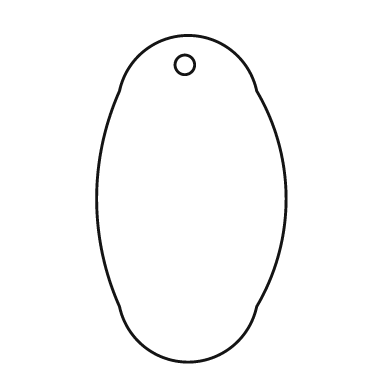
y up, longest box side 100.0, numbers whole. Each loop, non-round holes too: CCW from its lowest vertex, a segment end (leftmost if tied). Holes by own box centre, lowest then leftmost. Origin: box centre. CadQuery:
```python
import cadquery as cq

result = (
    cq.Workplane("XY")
    .moveTo(-22.0, -33.0)
    .threePointArc((-1.0, -50.0), (20.0, -33.0))
    .threePointArc((29.0, 0.0), (20.0, 33.0))
    .threePointArc((-1.0, 50.0), (-22.0, 33.0))
    .threePointArc((-29.0, 0.0), (-22.0, -33.0))
    .close()
    .moveTo(-2.0, 41.0)
    .circle(3.0)
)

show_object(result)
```